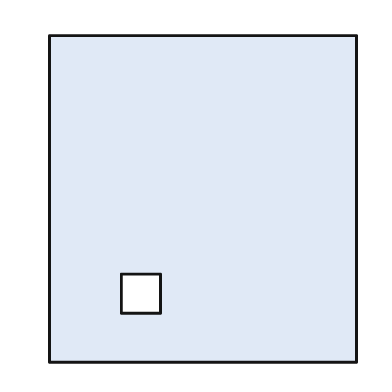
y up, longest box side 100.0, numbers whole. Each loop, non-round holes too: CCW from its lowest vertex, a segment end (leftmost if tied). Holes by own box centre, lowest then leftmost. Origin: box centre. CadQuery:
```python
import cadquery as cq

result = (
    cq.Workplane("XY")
    .moveTo(-47.0, -50.0)
    .lineTo(47.0, -50.0)
    .lineTo(47.0, 50.0)
    .lineTo(-47.0, 50.0)
    .close()
    .moveTo(-25.0, -35.0)
    .lineTo(-13.0, -35.0)
    .lineTo(-13.0, -23.0)
    .lineTo(-25.0, -23.0)
    .close()
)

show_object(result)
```